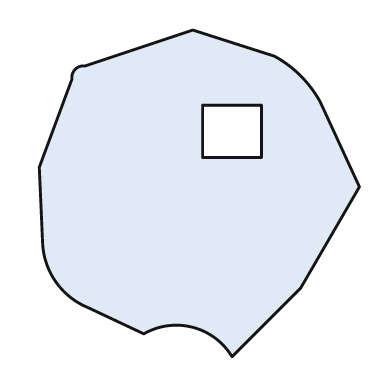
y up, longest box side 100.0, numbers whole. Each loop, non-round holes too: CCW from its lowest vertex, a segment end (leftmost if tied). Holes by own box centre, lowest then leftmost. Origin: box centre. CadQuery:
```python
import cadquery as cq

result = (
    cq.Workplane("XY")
    .moveTo(10.0, -50.0)
    .lineTo(31.0, -29.0)
    .lineTo(49.0, 2.0)
    .lineTo(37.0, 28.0)
    .threePointArc((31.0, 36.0), (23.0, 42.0))
    .lineTo(-2.0, 50.0)
    .lineTo(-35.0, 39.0)
    .threePointArc((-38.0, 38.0), (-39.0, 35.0))
    .lineTo(-49.0, 8.0)
    .lineTo(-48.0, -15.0)
    .threePointArc((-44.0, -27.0), (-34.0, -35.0))
    .lineTo(-17.0, -43.0)
    .threePointArc((-2.0, -41.0), (10.0, -50.0))
    .close()
    .moveTo(1.0, 11.0)
    .lineTo(19.0, 11.0)
    .lineTo(19.0, 27.0)
    .lineTo(1.0, 27.0)
    .close()
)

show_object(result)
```